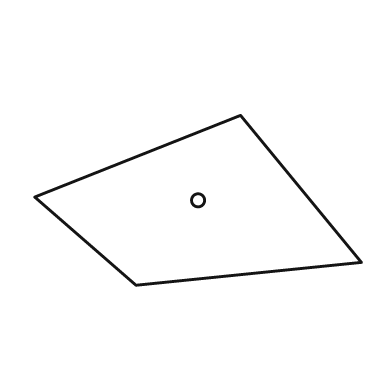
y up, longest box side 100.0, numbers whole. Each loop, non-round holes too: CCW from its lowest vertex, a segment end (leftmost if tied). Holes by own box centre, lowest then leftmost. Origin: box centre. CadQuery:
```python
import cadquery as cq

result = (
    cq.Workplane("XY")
    .moveTo(-19.0, -26.0)
    .lineTo(50.0, -19.0)
    .lineTo(13.0, 26.0)
    .lineTo(-50.0, 1.0)
    .close()
    .moveTo(0.0, 0.0)
    .circle(2.0)
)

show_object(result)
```